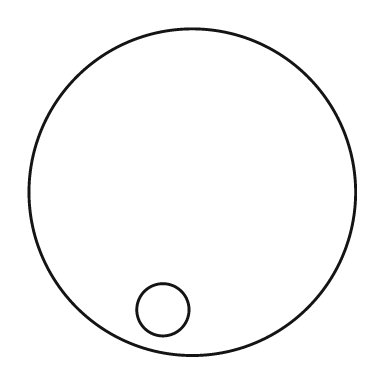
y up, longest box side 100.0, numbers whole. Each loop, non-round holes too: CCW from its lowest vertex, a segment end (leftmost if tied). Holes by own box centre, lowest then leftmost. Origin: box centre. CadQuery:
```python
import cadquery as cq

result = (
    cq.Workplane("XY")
    .moveTo(0.0, 0.0)
    .circle(50.0)
    .moveTo(-9.0, -36.0)
    .circle(8.0)
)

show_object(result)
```